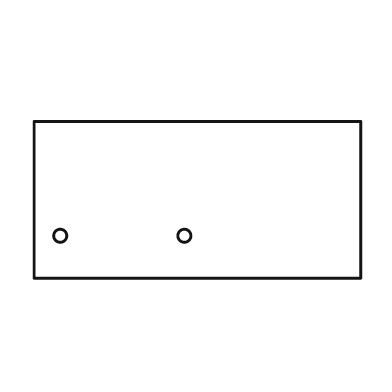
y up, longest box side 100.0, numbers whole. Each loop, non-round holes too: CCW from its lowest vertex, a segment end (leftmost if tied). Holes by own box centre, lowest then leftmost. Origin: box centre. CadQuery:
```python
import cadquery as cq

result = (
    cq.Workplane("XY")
    .moveTo(-50.0, -24.0)
    .lineTo(50.0, -24.0)
    .lineTo(50.0, 24.0)
    .lineTo(-50.0, 24.0)
    .close()
    .moveTo(-42.0, -11.0)
    .circle(2.0)
    .moveTo(-4.0, -11.0)
    .circle(2.0)
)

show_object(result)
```